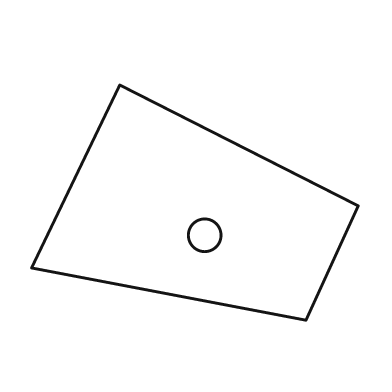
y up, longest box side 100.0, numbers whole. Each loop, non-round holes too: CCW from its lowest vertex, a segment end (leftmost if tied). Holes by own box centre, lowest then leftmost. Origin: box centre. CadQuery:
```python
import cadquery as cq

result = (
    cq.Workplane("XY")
    .moveTo(34.0, -36.0)
    .lineTo(50.0, -1.0)
    .lineTo(-23.0, 36.0)
    .lineTo(-50.0, -20.0)
    .close()
    .moveTo(3.0, -10.0)
    .circle(5.0)
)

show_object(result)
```